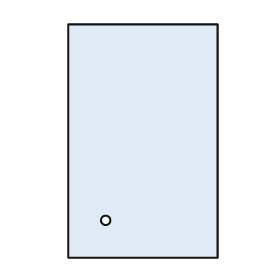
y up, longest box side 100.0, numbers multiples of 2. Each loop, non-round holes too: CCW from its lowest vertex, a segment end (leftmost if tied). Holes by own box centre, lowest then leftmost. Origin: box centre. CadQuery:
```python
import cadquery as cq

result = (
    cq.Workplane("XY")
    .moveTo(-32.0, -50.0)
    .lineTo(32.0, -50.0)
    .lineTo(32.0, 50.0)
    .lineTo(-32.0, 50.0)
    .close()
    .moveTo(-16.0, -34.0)
    .circle(2.0)
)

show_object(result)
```